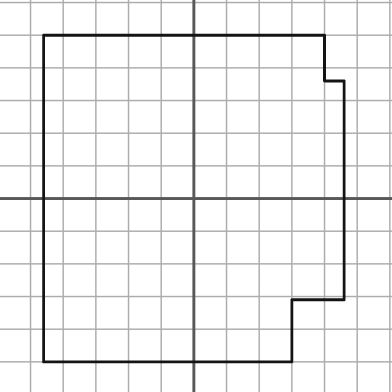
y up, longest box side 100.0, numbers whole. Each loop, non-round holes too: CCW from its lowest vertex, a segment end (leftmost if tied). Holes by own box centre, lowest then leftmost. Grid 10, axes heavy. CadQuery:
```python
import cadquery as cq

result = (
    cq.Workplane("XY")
    .moveTo(-46.0, -50.0)
    .lineTo(30.0, -50.0)
    .lineTo(30.0, -31.0)
    .lineTo(46.0, -31.0)
    .lineTo(46.0, 36.0)
    .lineTo(40.0, 36.0)
    .lineTo(40.0, 50.0)
    .lineTo(-46.0, 50.0)
    .close()
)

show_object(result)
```